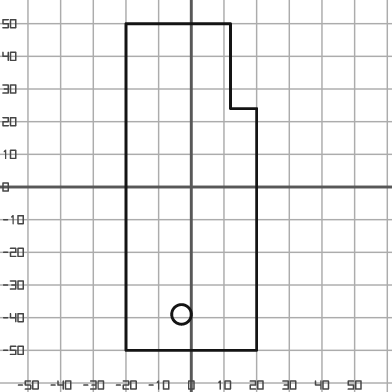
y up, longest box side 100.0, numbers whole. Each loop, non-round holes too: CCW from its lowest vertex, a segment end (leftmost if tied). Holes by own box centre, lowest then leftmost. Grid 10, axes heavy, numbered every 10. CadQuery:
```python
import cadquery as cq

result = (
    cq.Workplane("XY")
    .moveTo(-20.0, -50.0)
    .lineTo(20.0, -50.0)
    .lineTo(20.0, 24.0)
    .lineTo(12.0, 24.0)
    .lineTo(12.0, 50.0)
    .lineTo(-20.0, 50.0)
    .close()
    .moveTo(-3.0, -39.0)
    .circle(3.0)
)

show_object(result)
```